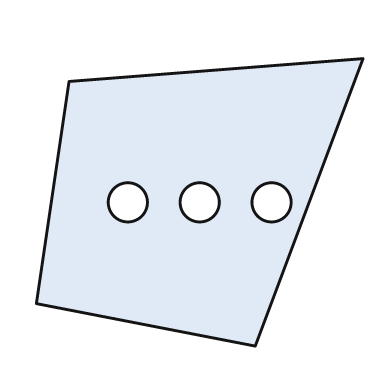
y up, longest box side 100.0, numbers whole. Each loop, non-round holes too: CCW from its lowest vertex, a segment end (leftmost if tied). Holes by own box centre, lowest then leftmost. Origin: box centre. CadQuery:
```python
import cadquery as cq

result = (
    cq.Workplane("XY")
    .moveTo(17.0, -44.0)
    .lineTo(50.0, 44.0)
    .lineTo(-40.0, 37.0)
    .lineTo(-50.0, -31.0)
    .close()
    .moveTo(-22.0, 0.0)
    .circle(6.0)
    .moveTo(0.0, 0.0)
    .circle(6.0)
    .moveTo(22.0, 0.0)
    .circle(6.0)
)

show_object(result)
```